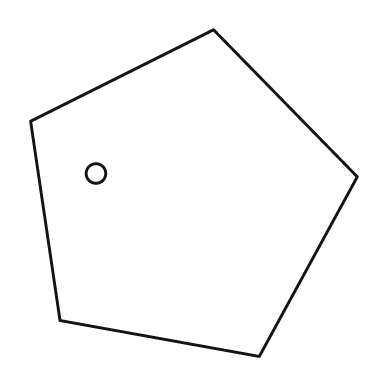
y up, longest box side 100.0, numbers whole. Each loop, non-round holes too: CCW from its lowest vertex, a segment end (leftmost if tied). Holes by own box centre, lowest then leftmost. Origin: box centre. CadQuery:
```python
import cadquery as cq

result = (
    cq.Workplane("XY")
    .moveTo(20.0, -50.0)
    .lineTo(50.0, 5.0)
    .lineTo(6.0, 50.0)
    .lineTo(-50.0, 22.0)
    .lineTo(-41.0, -39.0)
    .close()
    .moveTo(-30.0, 6.0)
    .circle(3.0)
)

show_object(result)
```